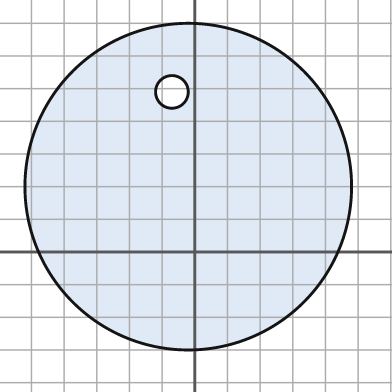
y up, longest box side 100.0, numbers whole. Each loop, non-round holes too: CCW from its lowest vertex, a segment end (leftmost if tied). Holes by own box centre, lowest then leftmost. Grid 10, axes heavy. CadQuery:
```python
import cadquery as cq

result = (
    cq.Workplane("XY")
    .moveTo(-2.0, 20.0)
    .circle(50.0)
    .moveTo(-7.0, 49.0)
    .circle(5.0)
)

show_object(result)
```